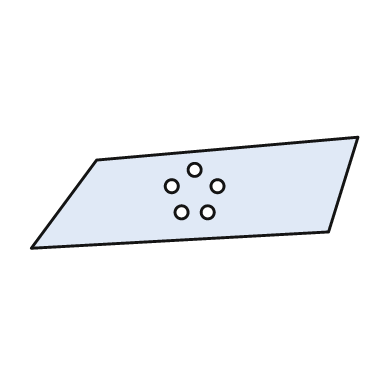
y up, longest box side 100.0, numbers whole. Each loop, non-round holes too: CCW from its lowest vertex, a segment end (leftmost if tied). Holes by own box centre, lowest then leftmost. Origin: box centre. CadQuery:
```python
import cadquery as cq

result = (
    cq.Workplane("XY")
    .moveTo(-50.0, -17.0)
    .lineTo(41.0, -12.0)
    .lineTo(50.0, 17.0)
    .lineTo(-30.0, 10.0)
    .close()
    .moveTo(-4.0, -6.0)
    .circle(2.0)
    .moveTo(4.0, -6.0)
    .circle(2.0)
    .moveTo(-7.0, 2.0)
    .circle(2.0)
    .moveTo(7.0, 2.0)
    .circle(2.0)
    .moveTo(0.0, 7.0)
    .circle(2.0)
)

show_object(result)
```